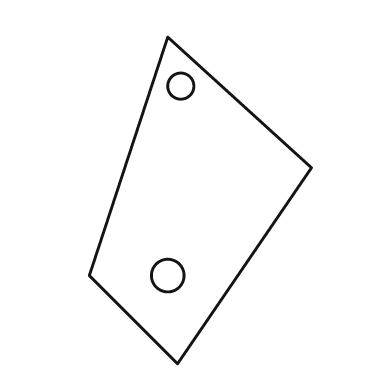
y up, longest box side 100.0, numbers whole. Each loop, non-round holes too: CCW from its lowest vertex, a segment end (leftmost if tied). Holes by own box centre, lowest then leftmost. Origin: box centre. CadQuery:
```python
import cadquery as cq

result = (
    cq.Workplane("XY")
    .moveTo(-7.0, -50.0)
    .lineTo(34.0, 10.0)
    .lineTo(-10.0, 50.0)
    .lineTo(-34.0, -23.0)
    .close()
    .moveTo(-10.0, -23.0)
    .circle(5.0)
    .moveTo(-6.0, 35.0)
    .circle(4.0)
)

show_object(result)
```